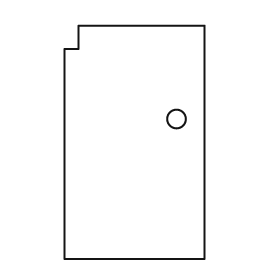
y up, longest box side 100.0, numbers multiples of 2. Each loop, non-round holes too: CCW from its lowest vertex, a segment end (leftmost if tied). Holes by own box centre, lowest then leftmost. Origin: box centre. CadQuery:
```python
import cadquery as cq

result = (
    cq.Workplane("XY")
    .moveTo(-30.0, -50.0)
    .lineTo(30.0, -50.0)
    .lineTo(30.0, 50.0)
    .lineTo(-24.0, 50.0)
    .lineTo(-24.0, 40.0)
    .lineTo(-30.0, 40.0)
    .close()
    .moveTo(18.0, 10.0)
    .circle(4.0)
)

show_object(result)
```